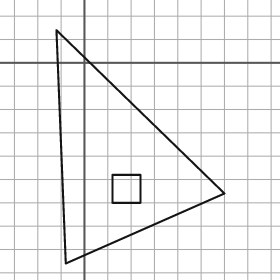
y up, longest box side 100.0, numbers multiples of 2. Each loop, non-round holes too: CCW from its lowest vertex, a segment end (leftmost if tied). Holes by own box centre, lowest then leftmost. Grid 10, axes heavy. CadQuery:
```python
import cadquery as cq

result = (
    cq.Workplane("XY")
    .moveTo(-8.0, -86.0)
    .lineTo(60.0, -56.0)
    .lineTo(-12.0, 14.0)
    .close()
    .moveTo(12.0, -60.0)
    .lineTo(24.0, -60.0)
    .lineTo(24.0, -48.0)
    .lineTo(12.0, -48.0)
    .close()
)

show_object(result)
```